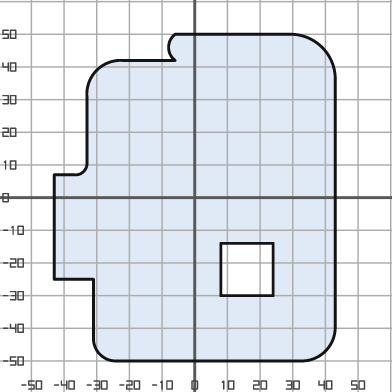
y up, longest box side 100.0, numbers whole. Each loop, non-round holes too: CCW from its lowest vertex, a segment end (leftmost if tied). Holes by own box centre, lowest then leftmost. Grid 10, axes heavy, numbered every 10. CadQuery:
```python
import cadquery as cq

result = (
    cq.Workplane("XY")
    .moveTo(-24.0, -50.0)
    .lineTo(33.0, -50.0)
    .threePointArc((40.0, -47.0), (43.0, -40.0))
    .lineTo(43.0, 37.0)
    .threePointArc((39.0, 46.0), (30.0, 50.0))
    .lineTo(-6.0, 50.0)
    .threePointArc((-8.0, 46.0), (-6.0, 42.0))
    .lineTo(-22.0, 42.0)
    .threePointArc((-30.0, 39.0), (-33.0, 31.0))
    .lineTo(-33.0, 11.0)
    .threePointArc((-34.0, 8.0), (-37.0, 7.0))
    .lineTo(-43.0, 7.0)
    .lineTo(-43.0, -25.0)
    .lineTo(-31.0, -25.0)
    .lineTo(-31.0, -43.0)
    .threePointArc((-29.0, -48.0), (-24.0, -50.0))
    .close()
    .moveTo(8.0, -30.0)
    .lineTo(24.0, -30.0)
    .lineTo(24.0, -14.0)
    .lineTo(8.0, -14.0)
    .close()
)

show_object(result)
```